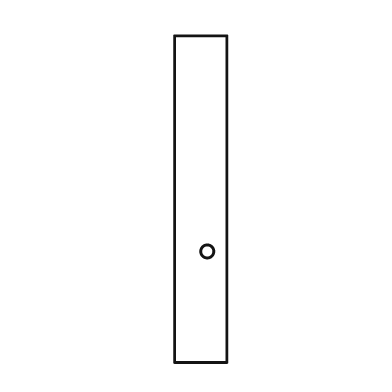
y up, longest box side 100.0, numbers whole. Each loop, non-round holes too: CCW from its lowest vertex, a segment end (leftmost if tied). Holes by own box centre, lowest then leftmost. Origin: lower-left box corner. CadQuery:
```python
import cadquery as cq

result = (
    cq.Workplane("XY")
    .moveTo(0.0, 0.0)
    .lineTo(16.0, 0.0)
    .lineTo(16.0, 100.0)
    .lineTo(0.0, 100.0)
    .close()
    .moveTo(10.0, 34.0)
    .circle(2.0)
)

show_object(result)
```